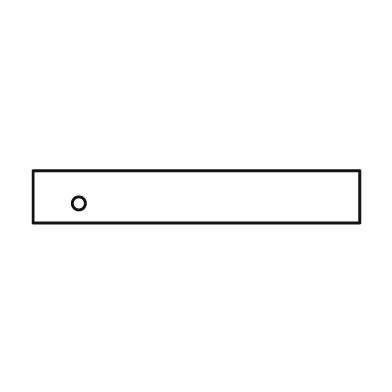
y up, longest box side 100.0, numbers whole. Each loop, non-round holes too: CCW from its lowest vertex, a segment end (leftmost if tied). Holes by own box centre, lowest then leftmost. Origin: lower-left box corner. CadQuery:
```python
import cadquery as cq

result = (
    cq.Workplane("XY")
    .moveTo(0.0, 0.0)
    .lineTo(100.0, 0.0)
    .lineTo(100.0, 16.0)
    .lineTo(0.0, 16.0)
    .close()
    .moveTo(14.0, 6.0)
    .circle(2.0)
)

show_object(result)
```